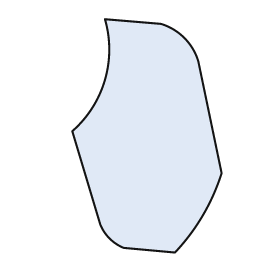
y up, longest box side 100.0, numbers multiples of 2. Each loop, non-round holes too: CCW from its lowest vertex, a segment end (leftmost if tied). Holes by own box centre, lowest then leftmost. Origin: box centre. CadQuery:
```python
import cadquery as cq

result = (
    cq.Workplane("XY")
    .moveTo(12.0, -50.0)
    .threePointArc((24.0, -34.0), (32.0, -16.0))
    .lineTo(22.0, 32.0)
    .threePointArc((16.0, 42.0), (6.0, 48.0))
    .lineTo(-18.0, 50.0)
    .threePointArc((-18.0, 24.0), (-32.0, 2.0))
    .lineTo(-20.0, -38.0)
    .threePointArc((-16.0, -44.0), (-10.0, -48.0))
    .close()
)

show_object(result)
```